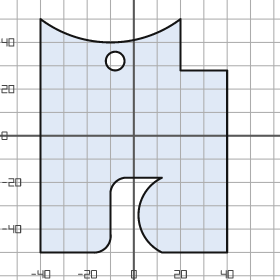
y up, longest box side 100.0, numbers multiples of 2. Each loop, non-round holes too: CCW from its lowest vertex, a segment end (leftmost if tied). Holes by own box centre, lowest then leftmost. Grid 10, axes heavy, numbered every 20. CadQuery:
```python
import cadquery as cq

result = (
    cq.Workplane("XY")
    .moveTo(-40.0, -50.0)
    .lineTo(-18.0, -50.0)
    .threePointArc((-12.0, -48.0), (-10.0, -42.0))
    .lineTo(-10.0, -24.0)
    .threePointArc((-8.0, -20.0), (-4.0, -18.0))
    .lineTo(12.0, -18.0)
    .threePointArc((2.0, -34.0), (12.0, -50.0))
    .lineTo(40.0, -50.0)
    .lineTo(40.0, 28.0)
    .lineTo(20.0, 28.0)
    .lineTo(20.0, 50.0)
    .threePointArc((-10.0, 40.0), (-40.0, 50.0))
    .close()
    .moveTo(-8.0, 32.0)
    .circle(4.0)
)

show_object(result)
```